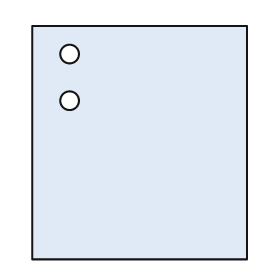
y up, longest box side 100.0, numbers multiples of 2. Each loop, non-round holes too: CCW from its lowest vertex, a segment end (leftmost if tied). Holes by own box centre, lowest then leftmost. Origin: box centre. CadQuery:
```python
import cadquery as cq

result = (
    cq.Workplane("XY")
    .moveTo(-46.0, -50.0)
    .lineTo(46.0, -50.0)
    .lineTo(46.0, 50.0)
    .lineTo(-46.0, 50.0)
    .close()
    .moveTo(-30.0, 18.0)
    .circle(4.0)
    .moveTo(-30.0, 38.0)
    .circle(4.0)
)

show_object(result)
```